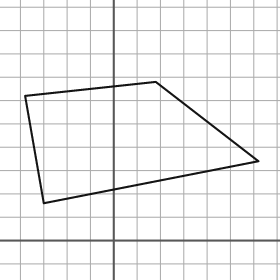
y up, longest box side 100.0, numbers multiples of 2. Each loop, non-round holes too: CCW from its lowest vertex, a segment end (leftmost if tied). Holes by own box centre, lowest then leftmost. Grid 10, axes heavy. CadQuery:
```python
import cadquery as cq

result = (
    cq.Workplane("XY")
    .moveTo(-30.0, 16.0)
    .lineTo(62.0, 34.0)
    .lineTo(18.0, 68.0)
    .lineTo(-38.0, 62.0)
    .close()
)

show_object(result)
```